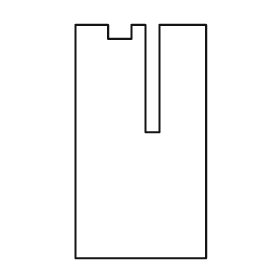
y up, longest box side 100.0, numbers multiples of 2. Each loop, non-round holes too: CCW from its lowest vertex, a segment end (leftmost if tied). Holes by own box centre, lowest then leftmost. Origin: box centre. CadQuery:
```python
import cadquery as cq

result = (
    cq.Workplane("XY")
    .moveTo(-28.0, -50.0)
    .lineTo(28.0, -50.0)
    .lineTo(28.0, 50.0)
    .lineTo(8.0, 50.0)
    .lineTo(8.0, 4.0)
    .lineTo(2.0, 4.0)
    .lineTo(2.0, 50.0)
    .lineTo(-4.0, 50.0)
    .lineTo(-4.0, 44.0)
    .lineTo(-14.0, 44.0)
    .lineTo(-14.0, 50.0)
    .lineTo(-28.0, 50.0)
    .close()
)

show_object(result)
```